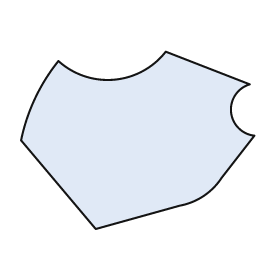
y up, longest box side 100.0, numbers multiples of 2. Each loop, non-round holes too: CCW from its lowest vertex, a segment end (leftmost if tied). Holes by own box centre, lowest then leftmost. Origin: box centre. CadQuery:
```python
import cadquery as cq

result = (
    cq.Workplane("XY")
    .moveTo(-18.0, -38.0)
    .lineTo(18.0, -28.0)
    .threePointArc((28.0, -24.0), (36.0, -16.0))
    .lineTo(50.0, 2.0)
    .threePointArc((40.0, 12.0), (48.0, 24.0))
    .lineTo(12.0, 38.0)
    .threePointArc((-10.0, 26.0), (-34.0, 34.0))
    .threePointArc((-44.0, 18.0), (-50.0, 0.0))
    .close()
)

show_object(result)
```